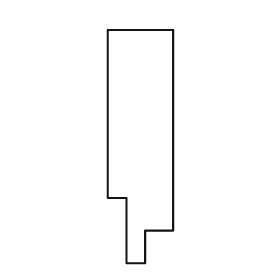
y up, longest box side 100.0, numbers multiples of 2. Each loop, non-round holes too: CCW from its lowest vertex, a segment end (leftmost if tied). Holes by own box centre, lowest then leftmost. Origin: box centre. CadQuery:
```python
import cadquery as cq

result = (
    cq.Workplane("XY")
    .moveTo(-6.0, -50.0)
    .lineTo(2.0, -50.0)
    .lineTo(2.0, -36.0)
    .lineTo(14.0, -36.0)
    .lineTo(14.0, 50.0)
    .lineTo(-14.0, 50.0)
    .lineTo(-14.0, -22.0)
    .lineTo(-6.0, -22.0)
    .close()
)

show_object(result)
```